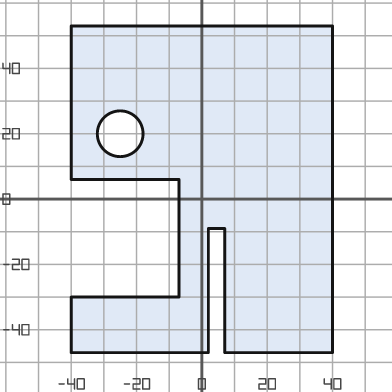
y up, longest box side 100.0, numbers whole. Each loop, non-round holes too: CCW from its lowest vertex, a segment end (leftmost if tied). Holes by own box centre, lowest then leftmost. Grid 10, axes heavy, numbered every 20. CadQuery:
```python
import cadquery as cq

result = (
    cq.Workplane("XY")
    .moveTo(-40.0, -47.0)
    .lineTo(2.0, -47.0)
    .lineTo(2.0, -9.0)
    .lineTo(7.0, -9.0)
    .lineTo(7.0, -47.0)
    .lineTo(40.0, -47.0)
    .lineTo(40.0, 53.0)
    .lineTo(-40.0, 53.0)
    .lineTo(-40.0, 6.0)
    .lineTo(-7.0, 6.0)
    .lineTo(-7.0, -30.0)
    .lineTo(-40.0, -30.0)
    .close()
    .moveTo(-25.0, 20.0)
    .circle(7.0)
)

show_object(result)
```